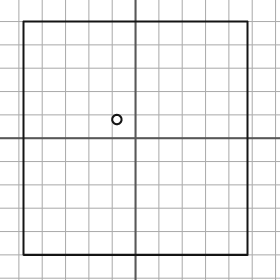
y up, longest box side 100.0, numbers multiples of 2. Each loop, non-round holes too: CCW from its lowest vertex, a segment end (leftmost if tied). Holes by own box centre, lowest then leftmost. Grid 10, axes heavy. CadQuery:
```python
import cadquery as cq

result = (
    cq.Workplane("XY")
    .moveTo(-48.0, -50.0)
    .lineTo(48.0, -50.0)
    .lineTo(48.0, 50.0)
    .lineTo(-48.0, 50.0)
    .close()
    .moveTo(-8.0, 8.0)
    .circle(2.0)
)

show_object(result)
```